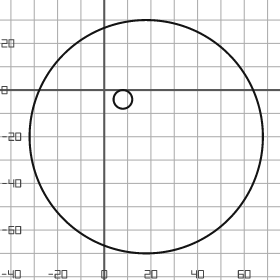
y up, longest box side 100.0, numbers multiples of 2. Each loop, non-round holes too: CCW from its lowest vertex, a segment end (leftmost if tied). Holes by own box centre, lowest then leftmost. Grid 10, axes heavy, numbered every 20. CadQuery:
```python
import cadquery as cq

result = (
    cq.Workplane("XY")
    .moveTo(18.0, -20.0)
    .circle(50.0)
    .moveTo(8.0, -4.0)
    .circle(4.0)
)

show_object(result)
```